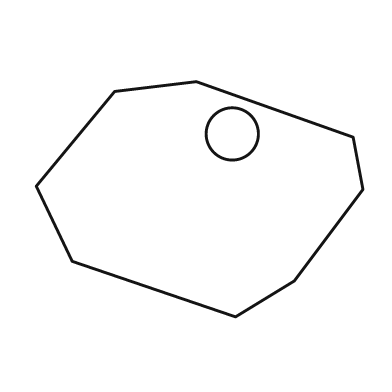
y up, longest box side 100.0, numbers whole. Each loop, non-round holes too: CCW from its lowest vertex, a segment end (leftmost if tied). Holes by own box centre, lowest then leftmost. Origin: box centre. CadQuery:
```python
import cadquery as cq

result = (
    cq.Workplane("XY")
    .moveTo(11.0, -36.0)
    .lineTo(29.0, -25.0)
    .lineTo(50.0, 3.0)
    .lineTo(47.0, 19.0)
    .lineTo(-1.0, 36.0)
    .lineTo(-26.0, 33.0)
    .lineTo(-50.0, 4.0)
    .lineTo(-39.0, -19.0)
    .close()
    .moveTo(10.0, 20.0)
    .circle(8.0)
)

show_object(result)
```